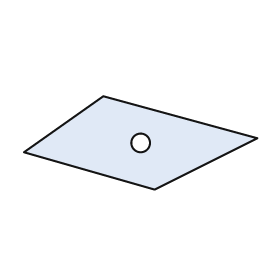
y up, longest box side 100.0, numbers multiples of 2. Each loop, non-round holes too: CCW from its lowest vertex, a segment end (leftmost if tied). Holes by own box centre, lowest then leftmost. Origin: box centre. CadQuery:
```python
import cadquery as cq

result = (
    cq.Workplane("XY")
    .moveTo(6.0, -20.0)
    .lineTo(50.0, 2.0)
    .lineTo(-16.0, 20.0)
    .lineTo(-50.0, -4.0)
    .close()
    .moveTo(0.0, 0.0)
    .circle(4.0)
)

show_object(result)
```